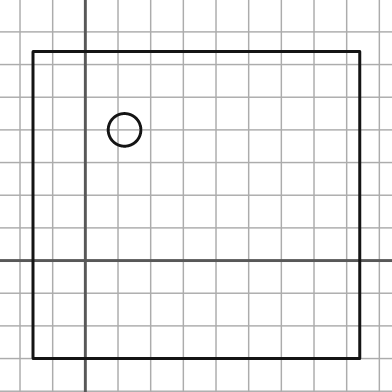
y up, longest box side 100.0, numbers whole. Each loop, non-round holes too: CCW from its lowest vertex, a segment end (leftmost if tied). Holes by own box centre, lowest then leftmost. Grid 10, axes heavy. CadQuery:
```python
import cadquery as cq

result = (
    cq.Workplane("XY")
    .moveTo(-16.0, -30.0)
    .lineTo(84.0, -30.0)
    .lineTo(84.0, 64.0)
    .lineTo(-16.0, 64.0)
    .close()
    .moveTo(12.0, 40.0)
    .circle(5.0)
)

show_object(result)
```